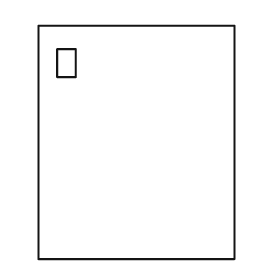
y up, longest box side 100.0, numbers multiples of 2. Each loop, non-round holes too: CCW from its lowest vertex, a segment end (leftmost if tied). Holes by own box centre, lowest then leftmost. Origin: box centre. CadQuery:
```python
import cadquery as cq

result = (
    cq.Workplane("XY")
    .moveTo(-42.0, -50.0)
    .lineTo(42.0, -50.0)
    .lineTo(42.0, 50.0)
    .lineTo(-42.0, 50.0)
    .close()
    .moveTo(-34.0, 28.0)
    .lineTo(-26.0, 28.0)
    .lineTo(-26.0, 40.0)
    .lineTo(-34.0, 40.0)
    .close()
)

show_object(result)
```